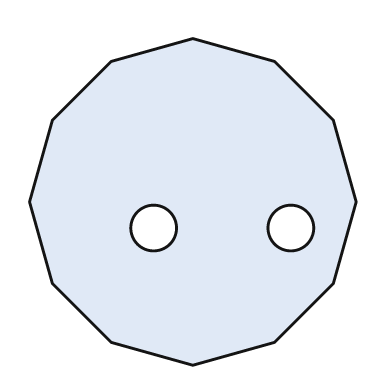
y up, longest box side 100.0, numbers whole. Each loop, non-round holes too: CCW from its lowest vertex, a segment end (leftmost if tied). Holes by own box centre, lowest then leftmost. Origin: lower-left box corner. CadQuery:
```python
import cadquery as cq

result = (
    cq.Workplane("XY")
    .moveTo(50.0, 0.0)
    .lineTo(75.0, 7.0)
    .lineTo(93.0, 25.0)
    .lineTo(100.0, 50.0)
    .lineTo(93.0, 75.0)
    .lineTo(75.0, 93.0)
    .lineTo(50.0, 100.0)
    .lineTo(25.0, 93.0)
    .lineTo(7.0, 75.0)
    .lineTo(0.0, 50.0)
    .lineTo(7.0, 25.0)
    .lineTo(25.0, 7.0)
    .close()
    .moveTo(38.0, 42.0)
    .circle(7.0)
    .moveTo(80.0, 42.0)
    .circle(7.0)
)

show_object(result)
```